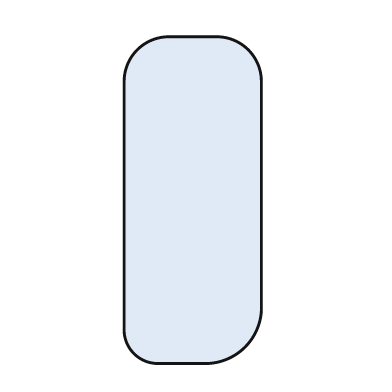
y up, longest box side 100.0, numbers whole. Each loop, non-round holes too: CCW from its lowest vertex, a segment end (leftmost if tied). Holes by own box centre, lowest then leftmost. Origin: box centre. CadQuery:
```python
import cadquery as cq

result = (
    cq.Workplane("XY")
    .moveTo(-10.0, -50.0)
    .lineTo(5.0, -50.0)
    .threePointArc((16.0, -45.0), (21.0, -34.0))
    .lineTo(21.0, 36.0)
    .threePointArc((17.0, 46.0), (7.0, 50.0))
    .lineTo(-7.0, 50.0)
    .threePointArc((-17.0, 46.0), (-21.0, 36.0))
    .lineTo(-21.0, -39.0)
    .threePointArc((-18.0, -47.0), (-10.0, -50.0))
    .close()
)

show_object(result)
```